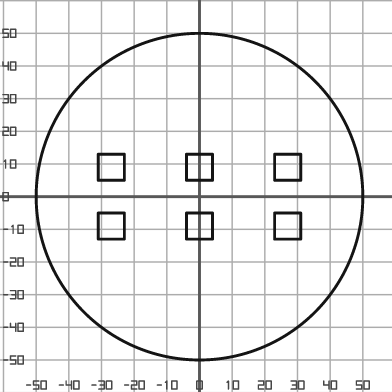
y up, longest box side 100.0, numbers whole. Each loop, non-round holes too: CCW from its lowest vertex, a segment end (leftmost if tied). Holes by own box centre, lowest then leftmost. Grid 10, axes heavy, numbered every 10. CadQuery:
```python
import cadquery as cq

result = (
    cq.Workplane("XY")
    .moveTo(0.0, 0.0)
    .circle(50.0)
    .moveTo(-31.0, -13.0)
    .lineTo(-23.0, -13.0)
    .lineTo(-23.0, -5.0)
    .lineTo(-31.0, -5.0)
    .close()
    .moveTo(-4.0, -13.0)
    .lineTo(4.0, -13.0)
    .lineTo(4.0, -5.0)
    .lineTo(-4.0, -5.0)
    .close()
    .moveTo(23.0, -13.0)
    .lineTo(31.0, -13.0)
    .lineTo(31.0, -5.0)
    .lineTo(23.0, -5.0)
    .close()
    .moveTo(-31.0, 5.0)
    .lineTo(-23.0, 5.0)
    .lineTo(-23.0, 13.0)
    .lineTo(-31.0, 13.0)
    .close()
    .moveTo(-4.0, 5.0)
    .lineTo(4.0, 5.0)
    .lineTo(4.0, 13.0)
    .lineTo(-4.0, 13.0)
    .close()
    .moveTo(23.0, 5.0)
    .lineTo(31.0, 5.0)
    .lineTo(31.0, 13.0)
    .lineTo(23.0, 13.0)
    .close()
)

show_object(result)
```